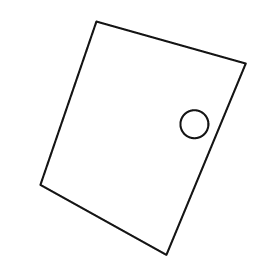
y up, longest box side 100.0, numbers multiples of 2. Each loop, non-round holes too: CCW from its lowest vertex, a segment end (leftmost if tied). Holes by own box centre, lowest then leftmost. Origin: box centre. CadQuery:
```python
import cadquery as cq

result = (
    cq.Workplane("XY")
    .moveTo(10.0, -50.0)
    .lineTo(44.0, 32.0)
    .lineTo(-20.0, 50.0)
    .lineTo(-44.0, -20.0)
    .close()
    .moveTo(22.0, 6.0)
    .circle(6.0)
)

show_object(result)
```